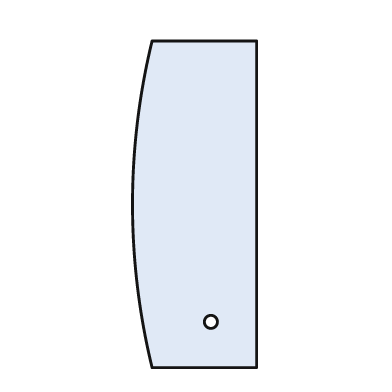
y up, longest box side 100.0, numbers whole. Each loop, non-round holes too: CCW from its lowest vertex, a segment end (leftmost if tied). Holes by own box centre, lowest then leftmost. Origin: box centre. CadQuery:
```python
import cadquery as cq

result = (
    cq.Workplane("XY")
    .moveTo(-13.0, -50.0)
    .lineTo(19.0, -50.0)
    .lineTo(19.0, 50.0)
    .lineTo(-13.0, 50.0)
    .threePointArc((-19.0, 0.0), (-13.0, -50.0))
    .close()
    .moveTo(5.0, -36.0)
    .circle(2.0)
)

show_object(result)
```